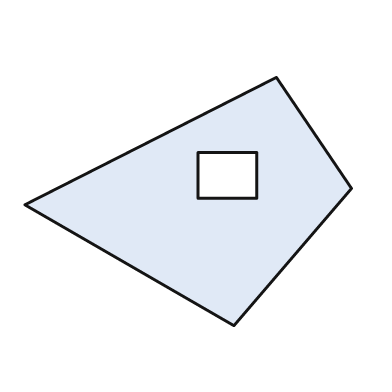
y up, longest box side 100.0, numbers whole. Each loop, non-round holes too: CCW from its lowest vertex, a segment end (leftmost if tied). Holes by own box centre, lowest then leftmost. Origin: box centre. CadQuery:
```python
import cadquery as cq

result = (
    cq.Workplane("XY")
    .moveTo(14.0, -38.0)
    .lineTo(50.0, 4.0)
    .lineTo(27.0, 38.0)
    .lineTo(-50.0, -1.0)
    .close()
    .moveTo(3.0, 1.0)
    .lineTo(21.0, 1.0)
    .lineTo(21.0, 15.0)
    .lineTo(3.0, 15.0)
    .close()
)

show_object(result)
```